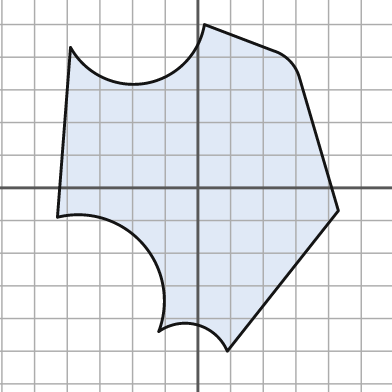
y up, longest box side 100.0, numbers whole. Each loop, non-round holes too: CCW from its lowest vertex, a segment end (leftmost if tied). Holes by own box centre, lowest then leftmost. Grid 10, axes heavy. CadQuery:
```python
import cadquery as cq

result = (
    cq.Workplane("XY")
    .moveTo(9.0, -50.0)
    .lineTo(43.0, -7.0)
    .lineTo(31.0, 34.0)
    .threePointArc((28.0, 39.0), (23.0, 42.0))
    .lineTo(2.0, 50.0)
    .threePointArc((-16.0, 32.0), (-39.0, 43.0))
    .lineTo(-43.0, -9.0)
    .threePointArc((-17.0, -17.0), (-12.0, -44.0))
    .threePointArc((0.0, -42.0), (9.0, -50.0))
    .close()
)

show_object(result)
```